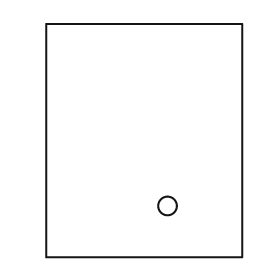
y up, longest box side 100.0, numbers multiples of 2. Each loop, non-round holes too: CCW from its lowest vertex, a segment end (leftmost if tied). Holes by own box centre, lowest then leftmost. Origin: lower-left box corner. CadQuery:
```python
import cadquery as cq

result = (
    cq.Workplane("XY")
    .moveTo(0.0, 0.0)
    .lineTo(84.0, 0.0)
    .lineTo(84.0, 100.0)
    .lineTo(0.0, 100.0)
    .close()
    .moveTo(52.0, 22.0)
    .circle(4.0)
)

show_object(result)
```